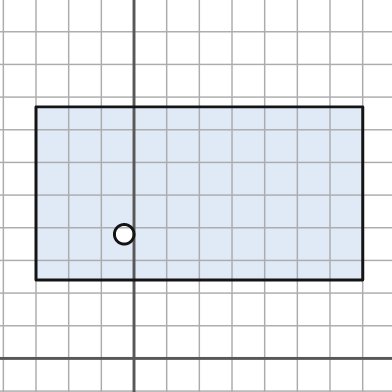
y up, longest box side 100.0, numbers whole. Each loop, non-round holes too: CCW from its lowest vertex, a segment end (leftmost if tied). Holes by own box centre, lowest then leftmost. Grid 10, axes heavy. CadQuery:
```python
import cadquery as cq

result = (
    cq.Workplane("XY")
    .moveTo(-30.0, 24.0)
    .lineTo(70.0, 24.0)
    .lineTo(70.0, 77.0)
    .lineTo(-30.0, 77.0)
    .close()
    .moveTo(-3.0, 38.0)
    .circle(3.0)
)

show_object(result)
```